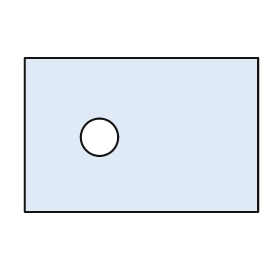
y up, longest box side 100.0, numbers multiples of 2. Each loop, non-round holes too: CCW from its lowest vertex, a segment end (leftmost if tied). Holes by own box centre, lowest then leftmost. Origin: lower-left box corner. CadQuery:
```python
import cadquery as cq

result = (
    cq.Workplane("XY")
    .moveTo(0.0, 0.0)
    .lineTo(100.0, 0.0)
    .lineTo(100.0, 66.0)
    .lineTo(0.0, 66.0)
    .close()
    .moveTo(32.0, 32.0)
    .circle(8.0)
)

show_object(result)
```